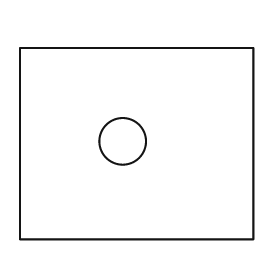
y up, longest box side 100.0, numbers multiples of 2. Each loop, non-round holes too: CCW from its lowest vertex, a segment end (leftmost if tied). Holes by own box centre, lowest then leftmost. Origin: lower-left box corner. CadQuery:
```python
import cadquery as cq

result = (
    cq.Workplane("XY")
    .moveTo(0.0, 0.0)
    .lineTo(100.0, 0.0)
    .lineTo(100.0, 82.0)
    .lineTo(0.0, 82.0)
    .close()
    .moveTo(44.0, 42.0)
    .circle(10.0)
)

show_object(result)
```